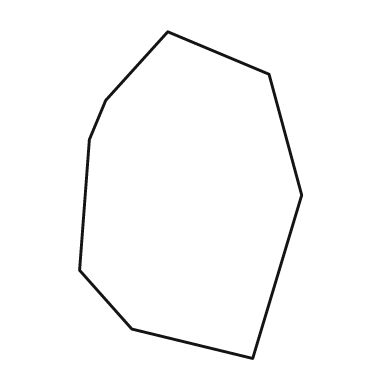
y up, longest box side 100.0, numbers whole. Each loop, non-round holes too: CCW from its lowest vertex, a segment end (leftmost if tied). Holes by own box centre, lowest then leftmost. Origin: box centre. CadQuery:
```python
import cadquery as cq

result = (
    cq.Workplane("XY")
    .moveTo(19.0, -50.0)
    .lineTo(34.0, 0.0)
    .lineTo(24.0, 37.0)
    .lineTo(-7.0, 50.0)
    .lineTo(-26.0, 29.0)
    .lineTo(-31.0, 17.0)
    .lineTo(-34.0, -23.0)
    .lineTo(-18.0, -41.0)
    .close()
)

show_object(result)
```